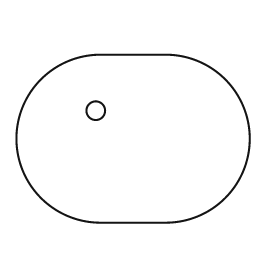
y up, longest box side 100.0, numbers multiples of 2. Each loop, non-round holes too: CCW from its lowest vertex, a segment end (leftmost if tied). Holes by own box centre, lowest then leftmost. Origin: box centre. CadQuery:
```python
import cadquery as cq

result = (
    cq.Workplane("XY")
    .moveTo(-14.0, -36.0)
    .lineTo(14.0, -36.0)
    .threePointArc((50.0, 0.0), (14.0, 36.0))
    .lineTo(-14.0, 36.0)
    .threePointArc((-50.0, 0.0), (-14.0, -36.0))
    .close()
    .moveTo(-16.0, 12.0)
    .circle(4.0)
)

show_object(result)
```